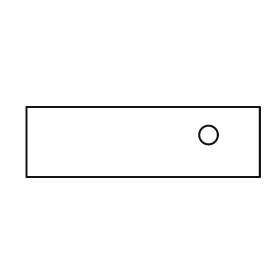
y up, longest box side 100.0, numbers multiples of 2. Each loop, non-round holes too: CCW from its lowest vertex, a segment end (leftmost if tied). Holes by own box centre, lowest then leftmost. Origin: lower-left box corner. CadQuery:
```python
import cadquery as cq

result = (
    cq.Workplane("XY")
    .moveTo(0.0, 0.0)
    .lineTo(100.0, 0.0)
    .lineTo(100.0, 30.0)
    .lineTo(0.0, 30.0)
    .close()
    .moveTo(78.0, 18.0)
    .circle(4.0)
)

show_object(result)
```